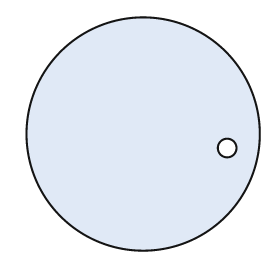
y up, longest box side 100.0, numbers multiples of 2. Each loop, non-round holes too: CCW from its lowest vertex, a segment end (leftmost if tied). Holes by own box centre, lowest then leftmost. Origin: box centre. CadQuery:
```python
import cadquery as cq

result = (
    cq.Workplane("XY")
    .moveTo(0.0, 0.0)
    .circle(50.0)
    .moveTo(36.0, -6.0)
    .circle(4.0)
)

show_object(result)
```